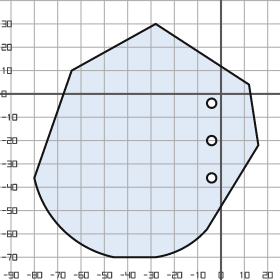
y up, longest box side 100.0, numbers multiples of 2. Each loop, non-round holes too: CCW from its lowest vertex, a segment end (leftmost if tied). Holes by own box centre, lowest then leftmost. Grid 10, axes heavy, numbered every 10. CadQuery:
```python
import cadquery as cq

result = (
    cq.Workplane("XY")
    .moveTo(-46.0, -70.0)
    .lineTo(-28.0, -70.0)
    .threePointArc((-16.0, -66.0), (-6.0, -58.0))
    .lineTo(16.0, -22.0)
    .lineTo(12.0, 4.0)
    .lineTo(-28.0, 30.0)
    .lineTo(-64.0, 10.0)
    .lineTo(-80.0, -36.0)
    .threePointArc((-68.0, -58.0), (-46.0, -70.0))
    .close()
    .moveTo(-4.0, -36.0)
    .circle(2.0)
    .moveTo(-4.0, -20.0)
    .circle(2.0)
    .moveTo(-4.0, -4.0)
    .circle(2.0)
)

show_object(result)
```